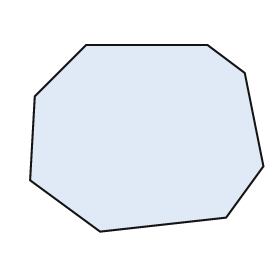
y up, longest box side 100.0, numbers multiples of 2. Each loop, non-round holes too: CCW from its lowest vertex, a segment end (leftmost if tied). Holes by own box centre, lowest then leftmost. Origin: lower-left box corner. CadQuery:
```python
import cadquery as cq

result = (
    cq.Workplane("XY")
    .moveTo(30.0, 0.0)
    .lineTo(84.0, 6.0)
    .lineTo(100.0, 28.0)
    .lineTo(92.0, 68.0)
    .lineTo(76.0, 80.0)
    .lineTo(24.0, 80.0)
    .lineTo(2.0, 58.0)
    .lineTo(0.0, 22.0)
    .close()
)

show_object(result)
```